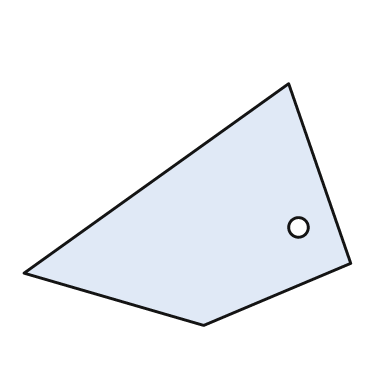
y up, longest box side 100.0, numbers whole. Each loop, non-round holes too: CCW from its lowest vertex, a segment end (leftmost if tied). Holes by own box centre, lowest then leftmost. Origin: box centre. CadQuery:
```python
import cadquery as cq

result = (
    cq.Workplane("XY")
    .moveTo(5.0, -37.0)
    .lineTo(50.0, -18.0)
    .lineTo(31.0, 37.0)
    .lineTo(-50.0, -21.0)
    .close()
    .moveTo(34.0, -7.0)
    .circle(3.0)
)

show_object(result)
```